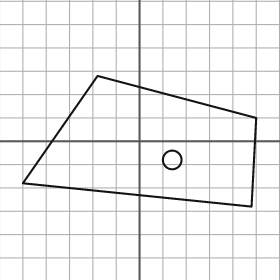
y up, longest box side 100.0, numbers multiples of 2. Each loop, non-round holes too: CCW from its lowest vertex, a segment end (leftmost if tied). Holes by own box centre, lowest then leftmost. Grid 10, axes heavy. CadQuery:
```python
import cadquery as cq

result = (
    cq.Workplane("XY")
    .moveTo(48.0, -28.0)
    .lineTo(50.0, 10.0)
    .lineTo(-18.0, 28.0)
    .lineTo(-50.0, -18.0)
    .close()
    .moveTo(14.0, -8.0)
    .circle(4.0)
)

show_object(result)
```